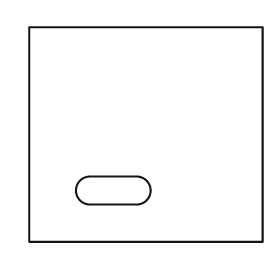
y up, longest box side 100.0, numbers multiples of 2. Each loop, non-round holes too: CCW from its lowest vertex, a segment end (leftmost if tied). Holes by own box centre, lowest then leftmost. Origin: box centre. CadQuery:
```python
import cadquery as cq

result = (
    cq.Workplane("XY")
    .moveTo(-50.0, -46.0)
    .lineTo(50.0, -46.0)
    .lineTo(50.0, 46.0)
    .lineTo(-50.0, 46.0)
    .close()
    .moveTo(-24.0, -30.0)
    .lineTo(-4.0, -30.0)
    .threePointArc((2.0, -24.0), (-4.0, -18.0))
    .lineTo(-24.0, -18.0)
    .threePointArc((-30.0, -24.0), (-24.0, -30.0))
    .close()
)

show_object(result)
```